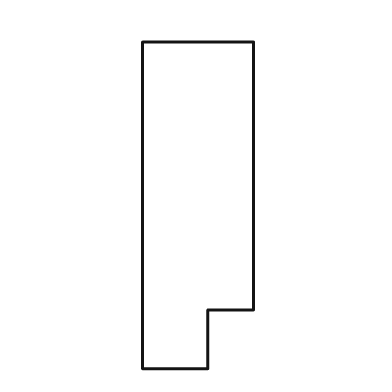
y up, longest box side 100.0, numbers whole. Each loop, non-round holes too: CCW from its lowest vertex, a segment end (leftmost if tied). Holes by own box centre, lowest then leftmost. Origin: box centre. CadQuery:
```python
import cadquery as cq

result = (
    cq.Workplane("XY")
    .moveTo(-17.0, -50.0)
    .lineTo(3.0, -50.0)
    .lineTo(3.0, -32.0)
    .lineTo(17.0, -32.0)
    .lineTo(17.0, 50.0)
    .lineTo(-17.0, 50.0)
    .close()
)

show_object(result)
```